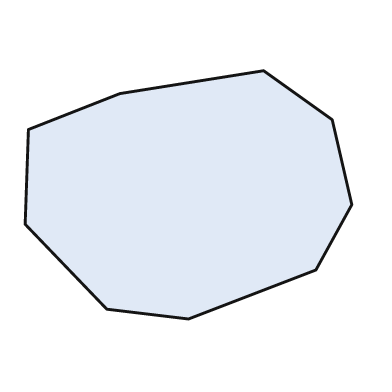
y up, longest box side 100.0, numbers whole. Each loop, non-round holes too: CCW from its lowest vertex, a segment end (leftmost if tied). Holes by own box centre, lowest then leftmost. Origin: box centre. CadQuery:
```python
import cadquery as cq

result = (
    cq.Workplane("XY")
    .moveTo(0.0, -38.0)
    .lineTo(39.0, -23.0)
    .lineTo(50.0, -3.0)
    .lineTo(44.0, 23.0)
    .lineTo(23.0, 38.0)
    .lineTo(-21.0, 31.0)
    .lineTo(-49.0, 20.0)
    .lineTo(-50.0, -9.0)
    .lineTo(-25.0, -35.0)
    .close()
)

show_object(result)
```